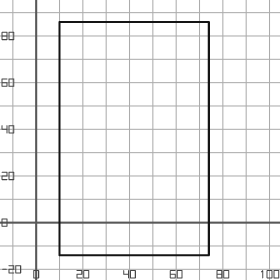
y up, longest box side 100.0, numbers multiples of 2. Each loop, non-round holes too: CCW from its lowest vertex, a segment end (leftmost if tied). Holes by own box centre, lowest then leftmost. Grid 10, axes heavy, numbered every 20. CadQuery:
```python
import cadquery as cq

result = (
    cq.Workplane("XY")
    .moveTo(10.0, -14.0)
    .lineTo(74.0, -14.0)
    .lineTo(74.0, 86.0)
    .lineTo(10.0, 86.0)
    .close()
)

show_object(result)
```